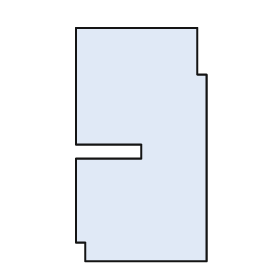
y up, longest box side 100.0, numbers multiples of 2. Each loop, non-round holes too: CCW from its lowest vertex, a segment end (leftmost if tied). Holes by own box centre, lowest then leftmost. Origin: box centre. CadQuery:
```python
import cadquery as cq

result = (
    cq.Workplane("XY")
    .moveTo(-24.0, -50.0)
    .lineTo(28.0, -50.0)
    .lineTo(28.0, 30.0)
    .lineTo(24.0, 30.0)
    .lineTo(24.0, 50.0)
    .lineTo(-28.0, 50.0)
    .lineTo(-28.0, 0.0)
    .lineTo(0.0, 0.0)
    .lineTo(0.0, -6.0)
    .lineTo(-28.0, -6.0)
    .lineTo(-28.0, -42.0)
    .lineTo(-24.0, -42.0)
    .close()
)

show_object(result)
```